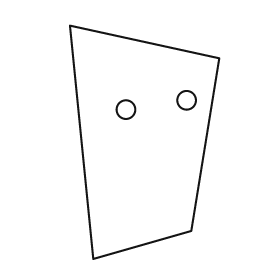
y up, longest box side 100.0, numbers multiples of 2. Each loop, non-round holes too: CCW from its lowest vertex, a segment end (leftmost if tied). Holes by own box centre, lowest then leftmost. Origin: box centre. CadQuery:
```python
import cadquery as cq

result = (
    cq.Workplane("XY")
    .moveTo(-22.0, -50.0)
    .lineTo(20.0, -38.0)
    .lineTo(32.0, 36.0)
    .lineTo(-32.0, 50.0)
    .close()
    .moveTo(-8.0, 14.0)
    .circle(4.0)
    .moveTo(18.0, 18.0)
    .circle(4.0)
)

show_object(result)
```